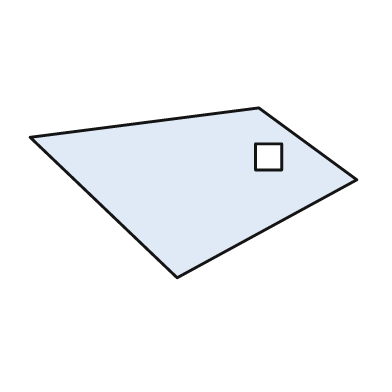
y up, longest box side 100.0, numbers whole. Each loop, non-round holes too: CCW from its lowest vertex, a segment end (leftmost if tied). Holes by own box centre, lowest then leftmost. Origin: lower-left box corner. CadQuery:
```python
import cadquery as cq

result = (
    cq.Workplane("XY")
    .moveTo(45.0, 0.0)
    .lineTo(100.0, 30.0)
    .lineTo(70.0, 52.0)
    .lineTo(0.0, 43.0)
    .close()
    .moveTo(69.0, 33.0)
    .lineTo(77.0, 33.0)
    .lineTo(77.0, 41.0)
    .lineTo(69.0, 41.0)
    .close()
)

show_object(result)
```